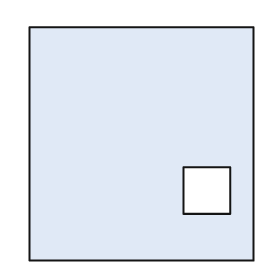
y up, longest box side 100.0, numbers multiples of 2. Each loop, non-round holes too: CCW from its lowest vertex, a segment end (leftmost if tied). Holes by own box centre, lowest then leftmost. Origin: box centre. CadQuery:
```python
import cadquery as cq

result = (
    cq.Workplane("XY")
    .moveTo(-48.0, -50.0)
    .lineTo(48.0, -50.0)
    .lineTo(48.0, 50.0)
    .lineTo(-48.0, 50.0)
    .close()
    .moveTo(18.0, -30.0)
    .lineTo(38.0, -30.0)
    .lineTo(38.0, -10.0)
    .lineTo(18.0, -10.0)
    .close()
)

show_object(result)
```